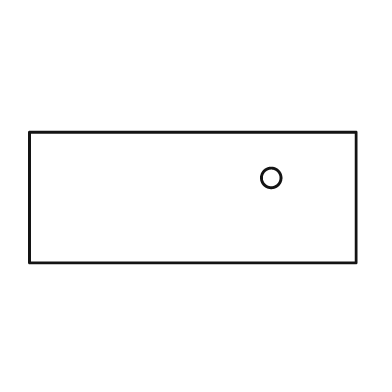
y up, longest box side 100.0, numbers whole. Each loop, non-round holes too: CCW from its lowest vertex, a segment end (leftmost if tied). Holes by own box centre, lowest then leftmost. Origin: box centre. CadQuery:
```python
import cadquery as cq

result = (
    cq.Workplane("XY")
    .moveTo(-50.0, -20.0)
    .lineTo(50.0, -20.0)
    .lineTo(50.0, 20.0)
    .lineTo(-50.0, 20.0)
    .close()
    .moveTo(24.0, 6.0)
    .circle(3.0)
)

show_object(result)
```